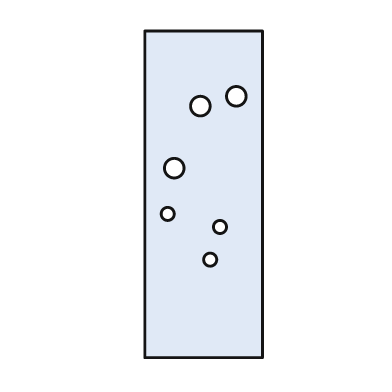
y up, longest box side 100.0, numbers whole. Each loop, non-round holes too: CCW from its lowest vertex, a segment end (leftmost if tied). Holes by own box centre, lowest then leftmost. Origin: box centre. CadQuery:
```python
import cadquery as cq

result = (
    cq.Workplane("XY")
    .moveTo(-18.0, -50.0)
    .lineTo(18.0, -50.0)
    .lineTo(18.0, 50.0)
    .lineTo(-18.0, 50.0)
    .close()
    .moveTo(2.0, -20.0)
    .circle(2.0)
    .moveTo(5.0, -10.0)
    .circle(2.0)
    .moveTo(-11.0, -6.0)
    .circle(2.0)
    .moveTo(-9.0, 8.0)
    .circle(3.0)
    .moveTo(-1.0, 27.0)
    .circle(3.0)
    .moveTo(10.0, 30.0)
    .circle(3.0)
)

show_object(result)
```